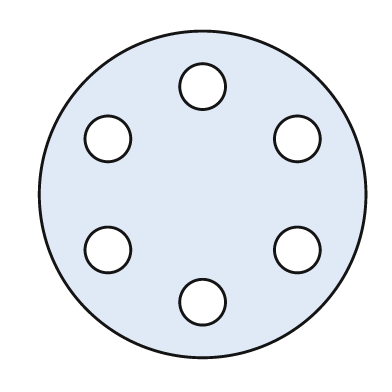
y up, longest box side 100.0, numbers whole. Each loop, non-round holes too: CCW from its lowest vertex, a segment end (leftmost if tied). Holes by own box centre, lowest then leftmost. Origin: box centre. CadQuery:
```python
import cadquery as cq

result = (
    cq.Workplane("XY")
    .moveTo(0.0, 0.0)
    .circle(50.0)
    .moveTo(0.0, -33.0)
    .circle(7.0)
    .moveTo(-29.0, -17.0)
    .circle(7.0)
    .moveTo(29.0, -17.0)
    .circle(7.0)
    .moveTo(-29.0, 17.0)
    .circle(7.0)
    .moveTo(29.0, 17.0)
    .circle(7.0)
    .moveTo(0.0, 33.0)
    .circle(7.0)
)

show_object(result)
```